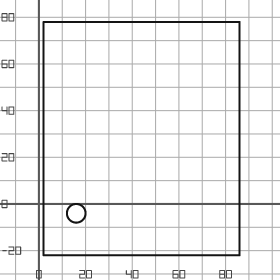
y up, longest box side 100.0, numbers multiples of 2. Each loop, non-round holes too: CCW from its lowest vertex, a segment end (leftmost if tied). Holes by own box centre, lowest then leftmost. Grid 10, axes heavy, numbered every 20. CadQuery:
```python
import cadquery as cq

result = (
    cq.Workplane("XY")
    .moveTo(2.0, -22.0)
    .lineTo(86.0, -22.0)
    .lineTo(86.0, 78.0)
    .lineTo(2.0, 78.0)
    .close()
    .moveTo(16.0, -4.0)
    .circle(4.0)
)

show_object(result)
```